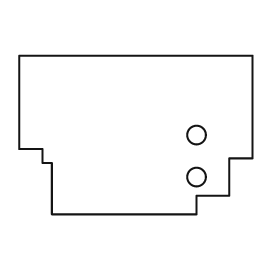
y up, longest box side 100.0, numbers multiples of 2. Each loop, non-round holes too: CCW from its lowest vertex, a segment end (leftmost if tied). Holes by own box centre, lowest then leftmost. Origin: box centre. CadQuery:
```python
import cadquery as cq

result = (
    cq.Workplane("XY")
    .moveTo(-36.0, -34.0)
    .lineTo(26.0, -34.0)
    .lineTo(26.0, -26.0)
    .lineTo(40.0, -26.0)
    .lineTo(40.0, -10.0)
    .lineTo(50.0, -10.0)
    .lineTo(50.0, 34.0)
    .lineTo(-50.0, 34.0)
    .lineTo(-50.0, -6.0)
    .lineTo(-40.0, -6.0)
    .lineTo(-40.0, -12.0)
    .lineTo(-36.0, -12.0)
    .close()
    .moveTo(26.0, -18.0)
    .circle(4.0)
    .moveTo(26.0, 0.0)
    .circle(4.0)
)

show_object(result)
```